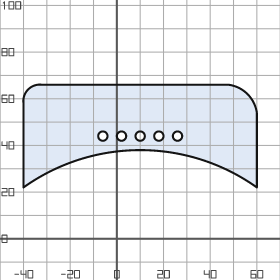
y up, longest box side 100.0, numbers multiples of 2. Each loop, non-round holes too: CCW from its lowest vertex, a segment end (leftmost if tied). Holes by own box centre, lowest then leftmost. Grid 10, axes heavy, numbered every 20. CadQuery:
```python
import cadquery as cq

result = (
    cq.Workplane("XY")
    .moveTo(-40.0, 22.0)
    .threePointArc((10.0, 38.0), (60.0, 22.0))
    .lineTo(60.0, 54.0)
    .threePointArc((56.0, 62.0), (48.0, 66.0))
    .lineTo(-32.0, 66.0)
    .threePointArc((-38.0, 64.0), (-40.0, 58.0))
    .close()
    .moveTo(-6.0, 44.0)
    .circle(2.0)
    .moveTo(2.0, 44.0)
    .circle(2.0)
    .moveTo(10.0, 44.0)
    .circle(2.0)
    .moveTo(18.0, 44.0)
    .circle(2.0)
    .moveTo(26.0, 44.0)
    .circle(2.0)
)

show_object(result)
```